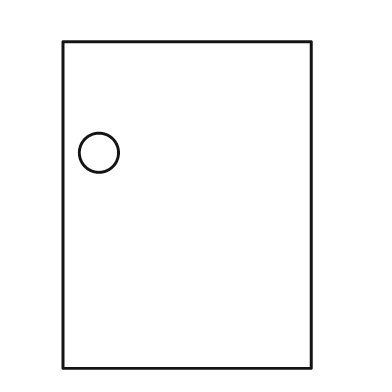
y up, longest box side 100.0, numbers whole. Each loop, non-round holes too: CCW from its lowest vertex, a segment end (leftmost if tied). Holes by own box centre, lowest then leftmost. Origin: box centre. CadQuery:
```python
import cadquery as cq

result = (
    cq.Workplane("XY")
    .moveTo(-38.0, -50.0)
    .lineTo(38.0, -50.0)
    .lineTo(38.0, 50.0)
    .lineTo(-38.0, 50.0)
    .close()
    .moveTo(-27.0, 16.0)
    .circle(6.0)
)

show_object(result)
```